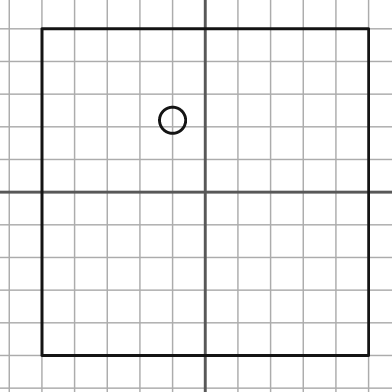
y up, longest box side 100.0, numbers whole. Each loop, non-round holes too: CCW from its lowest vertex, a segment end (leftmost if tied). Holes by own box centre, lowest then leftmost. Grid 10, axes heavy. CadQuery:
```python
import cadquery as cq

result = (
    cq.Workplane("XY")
    .moveTo(-50.0, -50.0)
    .lineTo(50.0, -50.0)
    .lineTo(50.0, 50.0)
    .lineTo(-50.0, 50.0)
    .close()
    .moveTo(-10.0, 22.0)
    .circle(4.0)
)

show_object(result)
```